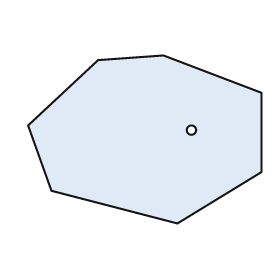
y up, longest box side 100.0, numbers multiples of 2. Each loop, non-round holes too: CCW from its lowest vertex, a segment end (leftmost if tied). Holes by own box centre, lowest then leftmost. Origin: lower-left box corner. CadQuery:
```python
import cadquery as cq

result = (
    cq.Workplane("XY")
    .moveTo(64.0, 0.0)
    .lineTo(100.0, 22.0)
    .lineTo(100.0, 56.0)
    .lineTo(58.0, 72.0)
    .lineTo(30.0, 70.0)
    .lineTo(0.0, 42.0)
    .lineTo(10.0, 14.0)
    .close()
    .moveTo(70.0, 40.0)
    .circle(2.0)
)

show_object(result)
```